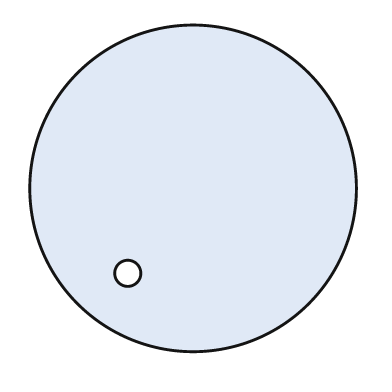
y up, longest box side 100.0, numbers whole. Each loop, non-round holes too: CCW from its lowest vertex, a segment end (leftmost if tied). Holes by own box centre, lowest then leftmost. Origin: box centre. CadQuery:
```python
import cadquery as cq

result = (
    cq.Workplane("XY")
    .moveTo(0.0, 0.0)
    .circle(50.0)
    .moveTo(-20.0, -26.0)
    .circle(4.0)
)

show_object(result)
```